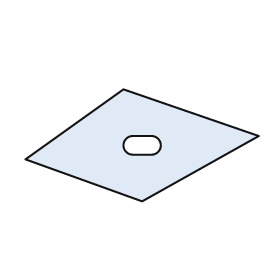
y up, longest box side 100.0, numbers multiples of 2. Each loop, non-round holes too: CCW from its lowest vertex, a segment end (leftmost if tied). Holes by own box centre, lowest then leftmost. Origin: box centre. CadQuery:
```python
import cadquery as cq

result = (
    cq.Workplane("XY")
    .moveTo(0.0, -24.0)
    .lineTo(50.0, 4.0)
    .lineTo(-8.0, 24.0)
    .lineTo(-50.0, -6.0)
    .close()
    .moveTo(-4.0, -4.0)
    .lineTo(4.0, -4.0)
    .threePointArc((8.0, 0.0), (4.0, 4.0))
    .lineTo(-4.0, 4.0)
    .threePointArc((-8.0, 0.0), (-4.0, -4.0))
    .close()
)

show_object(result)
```